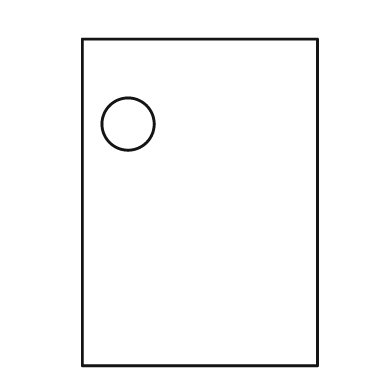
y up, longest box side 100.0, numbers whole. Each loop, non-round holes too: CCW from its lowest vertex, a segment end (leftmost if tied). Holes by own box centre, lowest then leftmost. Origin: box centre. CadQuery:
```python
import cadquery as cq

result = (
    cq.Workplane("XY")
    .moveTo(-36.0, -50.0)
    .lineTo(36.0, -50.0)
    .lineTo(36.0, 50.0)
    .lineTo(-36.0, 50.0)
    .close()
    .moveTo(-22.0, 24.0)
    .circle(8.0)
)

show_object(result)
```